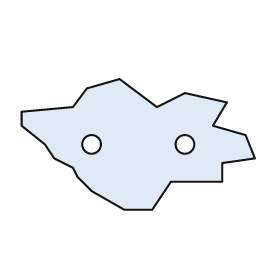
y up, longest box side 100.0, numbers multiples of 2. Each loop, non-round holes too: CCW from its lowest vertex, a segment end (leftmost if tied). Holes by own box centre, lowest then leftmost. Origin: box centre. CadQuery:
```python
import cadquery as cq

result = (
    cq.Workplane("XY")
    .moveTo(-6.0, -28.0)
    .lineTo(6.0, -28.0)
    .lineTo(14.0, -16.0)
    .lineTo(36.0, -16.0)
    .lineTo(36.0, -8.0)
    .lineTo(50.0, -6.0)
    .lineTo(46.0, 4.0)
    .lineTo(32.0, 8.0)
    .lineTo(38.0, 18.0)
    .lineTo(20.0, 22.0)
    .lineTo(8.0, 16.0)
    .lineTo(-8.0, 28.0)
    .lineTo(-22.0, 24.0)
    .lineTo(-28.0, 16.0)
    .lineTo(-50.0, 14.0)
    .lineTo(-50.0, 8.0)
    .lineTo(-40.0, 0.0)
    .lineTo(-36.0, -6.0)
    .lineTo(-28.0, -10.0)
    .lineTo(-26.0, -14.0)
    .lineTo(-20.0, -20.0)
    .close()
    .moveTo(-20.0, 0.0)
    .circle(4.0)
    .moveTo(20.0, 0.0)
    .circle(4.0)
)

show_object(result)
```